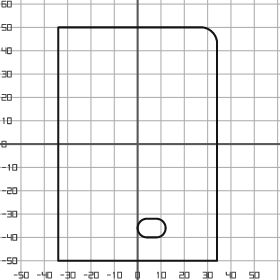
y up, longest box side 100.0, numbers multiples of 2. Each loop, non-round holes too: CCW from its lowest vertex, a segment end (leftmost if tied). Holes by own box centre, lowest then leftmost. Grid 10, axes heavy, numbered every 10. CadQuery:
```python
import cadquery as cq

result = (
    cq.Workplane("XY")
    .moveTo(-34.0, -50.0)
    .lineTo(34.0, -50.0)
    .lineTo(34.0, 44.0)
    .threePointArc((32.0, 48.0), (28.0, 50.0))
    .lineTo(-34.0, 50.0)
    .close()
    .moveTo(4.0, -40.0)
    .lineTo(8.0, -40.0)
    .threePointArc((12.0, -36.0), (8.0, -32.0))
    .lineTo(4.0, -32.0)
    .threePointArc((0.0, -36.0), (4.0, -40.0))
    .close()
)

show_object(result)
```